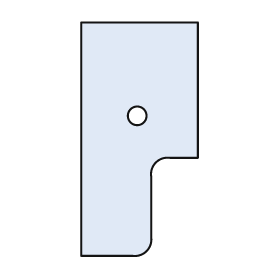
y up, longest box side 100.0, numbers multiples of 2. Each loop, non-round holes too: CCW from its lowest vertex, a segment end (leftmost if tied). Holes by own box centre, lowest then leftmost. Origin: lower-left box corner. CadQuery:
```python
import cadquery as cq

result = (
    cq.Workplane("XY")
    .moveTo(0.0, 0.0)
    .lineTo(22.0, 0.0)
    .threePointArc((28.0, 2.0), (30.0, 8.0))
    .lineTo(30.0, 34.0)
    .threePointArc((32.0, 40.0), (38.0, 42.0))
    .lineTo(50.0, 42.0)
    .lineTo(50.0, 100.0)
    .lineTo(0.0, 100.0)
    .close()
    .moveTo(24.0, 60.0)
    .circle(4.0)
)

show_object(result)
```